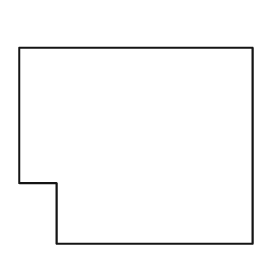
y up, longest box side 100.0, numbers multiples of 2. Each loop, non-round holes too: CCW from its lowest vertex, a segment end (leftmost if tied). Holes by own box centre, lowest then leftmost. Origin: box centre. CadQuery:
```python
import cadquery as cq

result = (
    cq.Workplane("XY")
    .moveTo(-34.0, -42.0)
    .lineTo(50.0, -42.0)
    .lineTo(50.0, 42.0)
    .lineTo(-50.0, 42.0)
    .lineTo(-50.0, -16.0)
    .lineTo(-34.0, -16.0)
    .close()
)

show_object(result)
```